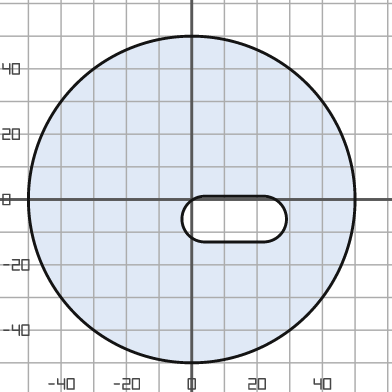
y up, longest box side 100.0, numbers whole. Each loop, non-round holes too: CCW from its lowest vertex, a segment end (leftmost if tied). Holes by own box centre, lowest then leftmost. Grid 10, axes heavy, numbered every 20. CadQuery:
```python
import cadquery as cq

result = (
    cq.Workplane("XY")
    .moveTo(0.0, 0.0)
    .circle(50.0)
    .moveTo(4.0, -13.0)
    .lineTo(22.0, -13.0)
    .threePointArc((29.0, -6.0), (22.0, 1.0))
    .lineTo(4.0, 1.0)
    .threePointArc((-3.0, -6.0), (4.0, -13.0))
    .close()
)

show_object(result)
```